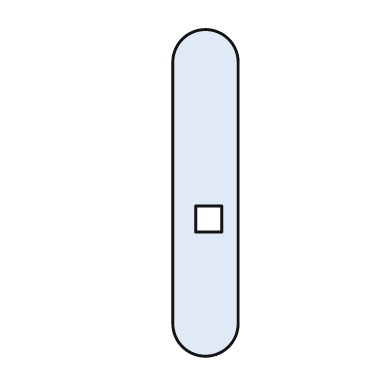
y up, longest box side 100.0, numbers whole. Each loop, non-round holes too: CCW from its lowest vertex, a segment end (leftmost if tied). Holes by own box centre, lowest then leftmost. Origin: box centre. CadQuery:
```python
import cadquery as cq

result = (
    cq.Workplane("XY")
    .moveTo(-10.0, -40.0)
    .threePointArc((0.0, -50.0), (10.0, -40.0))
    .lineTo(10.0, 40.0)
    .threePointArc((0.0, 50.0), (-10.0, 40.0))
    .close()
    .moveTo(-3.0, -12.0)
    .lineTo(5.0, -12.0)
    .lineTo(5.0, -4.0)
    .lineTo(-3.0, -4.0)
    .close()
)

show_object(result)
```